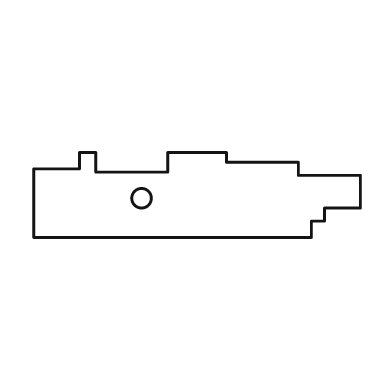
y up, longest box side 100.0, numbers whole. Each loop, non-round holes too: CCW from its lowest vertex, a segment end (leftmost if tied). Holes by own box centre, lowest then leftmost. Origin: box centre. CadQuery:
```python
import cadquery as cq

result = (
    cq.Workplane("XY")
    .moveTo(-50.0, -13.0)
    .lineTo(35.0, -13.0)
    .lineTo(35.0, -8.0)
    .lineTo(39.0, -8.0)
    .lineTo(39.0, -4.0)
    .lineTo(50.0, -4.0)
    .lineTo(50.0, 6.0)
    .lineTo(31.0, 6.0)
    .lineTo(31.0, 10.0)
    .lineTo(9.0, 10.0)
    .lineTo(9.0, 13.0)
    .lineTo(-9.0, 13.0)
    .lineTo(-9.0, 7.0)
    .lineTo(-31.0, 7.0)
    .lineTo(-31.0, 13.0)
    .lineTo(-36.0, 13.0)
    .lineTo(-36.0, 8.0)
    .lineTo(-50.0, 8.0)
    .close()
    .moveTo(-17.0, -1.0)
    .circle(3.0)
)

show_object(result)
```